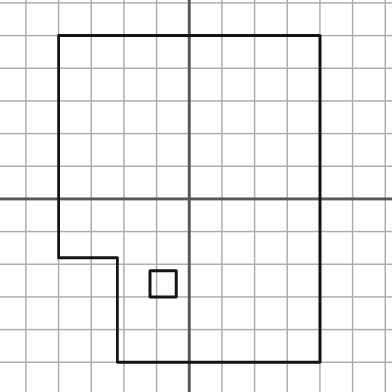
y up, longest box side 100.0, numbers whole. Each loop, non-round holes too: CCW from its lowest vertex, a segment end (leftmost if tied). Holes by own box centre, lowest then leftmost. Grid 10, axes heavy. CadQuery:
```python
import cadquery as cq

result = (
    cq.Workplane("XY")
    .moveTo(-22.0, -50.0)
    .lineTo(40.0, -50.0)
    .lineTo(40.0, 50.0)
    .lineTo(-40.0, 50.0)
    .lineTo(-40.0, -18.0)
    .lineTo(-22.0, -18.0)
    .close()
    .moveTo(-12.0, -30.0)
    .lineTo(-4.0, -30.0)
    .lineTo(-4.0, -22.0)
    .lineTo(-12.0, -22.0)
    .close()
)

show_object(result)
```